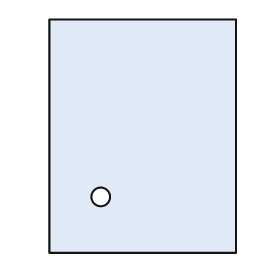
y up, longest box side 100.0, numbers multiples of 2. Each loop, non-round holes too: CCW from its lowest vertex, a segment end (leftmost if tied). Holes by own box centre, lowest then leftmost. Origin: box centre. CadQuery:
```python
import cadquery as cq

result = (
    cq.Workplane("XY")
    .moveTo(-40.0, -50.0)
    .lineTo(40.0, -50.0)
    .lineTo(40.0, 50.0)
    .lineTo(-40.0, 50.0)
    .close()
    .moveTo(-18.0, -26.0)
    .circle(4.0)
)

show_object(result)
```